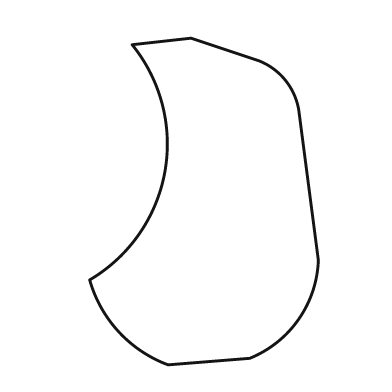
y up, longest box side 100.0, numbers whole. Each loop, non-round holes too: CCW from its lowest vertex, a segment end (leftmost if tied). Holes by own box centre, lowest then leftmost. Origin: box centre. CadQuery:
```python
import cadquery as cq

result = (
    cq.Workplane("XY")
    .moveTo(-11.0, -50.0)
    .lineTo(14.0, -48.0)
    .threePointArc((29.0, -36.0), (35.0, -18.0))
    .lineTo(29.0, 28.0)
    .threePointArc((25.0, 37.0), (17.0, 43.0))
    .lineTo(-4.0, 50.0)
    .lineTo(-22.0, 48.0)
    .threePointArc((-12.0, 9.0), (-35.0, -24.0))
    .threePointArc((-26.0, -40.0), (-11.0, -50.0))
    .close()
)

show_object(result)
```